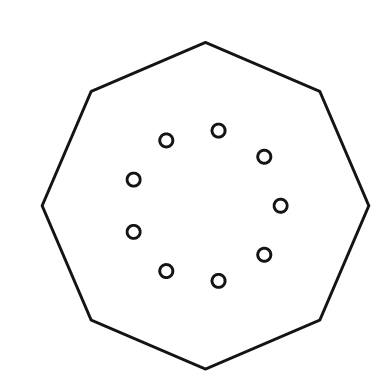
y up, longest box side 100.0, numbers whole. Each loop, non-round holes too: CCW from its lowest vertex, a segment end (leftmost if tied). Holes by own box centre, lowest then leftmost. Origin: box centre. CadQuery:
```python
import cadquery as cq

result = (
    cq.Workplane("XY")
    .moveTo(0.0, -50.0)
    .lineTo(35.0, -35.0)
    .lineTo(50.0, 0.0)
    .lineTo(35.0, 35.0)
    .lineTo(0.0, 50.0)
    .lineTo(-35.0, 35.0)
    .lineTo(-50.0, 0.0)
    .lineTo(-35.0, -35.0)
    .close()
    .moveTo(4.0, -23.0)
    .circle(2.0)
    .moveTo(-12.0, -20.0)
    .circle(2.0)
    .moveTo(18.0, -15.0)
    .circle(2.0)
    .moveTo(-22.0, -8.0)
    .circle(2.0)
    .moveTo(23.0, 0.0)
    .circle(2.0)
    .moveTo(-22.0, 8.0)
    .circle(2.0)
    .moveTo(18.0, 15.0)
    .circle(2.0)
    .moveTo(-12.0, 20.0)
    .circle(2.0)
    .moveTo(4.0, 23.0)
    .circle(2.0)
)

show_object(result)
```